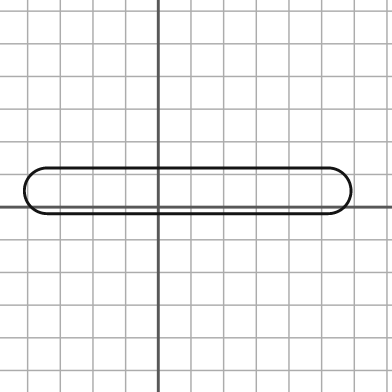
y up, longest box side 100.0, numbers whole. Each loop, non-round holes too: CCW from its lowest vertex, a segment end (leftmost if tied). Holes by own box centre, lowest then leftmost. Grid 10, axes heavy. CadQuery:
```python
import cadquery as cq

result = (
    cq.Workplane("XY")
    .moveTo(-34.0, -2.0)
    .lineTo(52.0, -2.0)
    .threePointArc((59.0, 5.0), (52.0, 12.0))
    .lineTo(-34.0, 12.0)
    .threePointArc((-41.0, 5.0), (-34.0, -2.0))
    .close()
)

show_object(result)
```